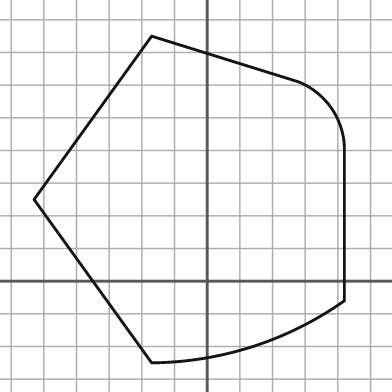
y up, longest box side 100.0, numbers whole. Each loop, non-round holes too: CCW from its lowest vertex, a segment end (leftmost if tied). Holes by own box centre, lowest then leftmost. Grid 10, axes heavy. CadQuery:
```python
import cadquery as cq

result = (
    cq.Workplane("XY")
    .moveTo(-17.0, -25.0)
    .threePointArc((14.0, -20.0), (42.0, -6.0))
    .lineTo(42.0, 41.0)
    .threePointArc((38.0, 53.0), (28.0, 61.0))
    .lineTo(-17.0, 75.0)
    .lineTo(-53.0, 25.0)
    .close()
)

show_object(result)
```